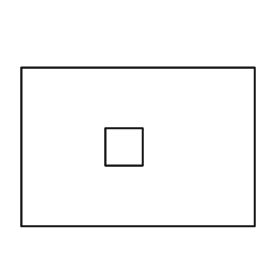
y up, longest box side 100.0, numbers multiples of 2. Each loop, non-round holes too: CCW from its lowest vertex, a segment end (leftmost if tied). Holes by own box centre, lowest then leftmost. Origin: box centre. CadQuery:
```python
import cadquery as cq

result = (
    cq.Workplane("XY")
    .moveTo(-50.0, -34.0)
    .lineTo(50.0, -34.0)
    .lineTo(50.0, 34.0)
    .lineTo(-50.0, 34.0)
    .close()
    .moveTo(-14.0, -8.0)
    .lineTo(2.0, -8.0)
    .lineTo(2.0, 8.0)
    .lineTo(-14.0, 8.0)
    .close()
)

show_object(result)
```